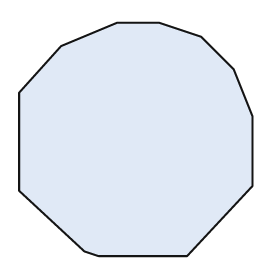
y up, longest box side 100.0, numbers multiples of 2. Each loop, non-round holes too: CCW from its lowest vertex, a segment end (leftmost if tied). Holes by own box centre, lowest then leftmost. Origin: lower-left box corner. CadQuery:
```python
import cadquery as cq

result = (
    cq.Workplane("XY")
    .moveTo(34.0, 0.0)
    .lineTo(72.0, 0.0)
    .lineTo(100.0, 30.0)
    .lineTo(100.0, 60.0)
    .lineTo(92.0, 80.0)
    .lineTo(78.0, 94.0)
    .lineTo(60.0, 100.0)
    .lineTo(42.0, 100.0)
    .lineTo(18.0, 90.0)
    .lineTo(0.0, 70.0)
    .lineTo(0.0, 28.0)
    .lineTo(28.0, 2.0)
    .close()
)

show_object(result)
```